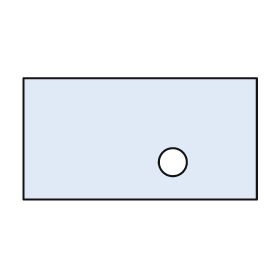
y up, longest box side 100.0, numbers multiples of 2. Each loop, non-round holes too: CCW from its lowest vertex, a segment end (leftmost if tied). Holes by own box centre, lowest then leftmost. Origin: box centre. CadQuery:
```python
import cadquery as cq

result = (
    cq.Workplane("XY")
    .moveTo(-50.0, -26.0)
    .lineTo(50.0, -26.0)
    .lineTo(50.0, 26.0)
    .lineTo(-50.0, 26.0)
    .close()
    .moveTo(14.0, -10.0)
    .circle(6.0)
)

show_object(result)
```